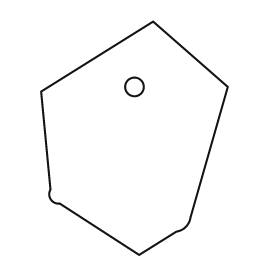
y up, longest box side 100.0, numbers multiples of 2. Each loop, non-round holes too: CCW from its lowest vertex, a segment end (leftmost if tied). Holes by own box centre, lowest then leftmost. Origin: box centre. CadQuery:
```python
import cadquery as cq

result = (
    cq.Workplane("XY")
    .moveTo(2.0, -50.0)
    .lineTo(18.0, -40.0)
    .threePointArc((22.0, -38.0), (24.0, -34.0))
    .lineTo(40.0, 22.0)
    .lineTo(8.0, 50.0)
    .lineTo(-40.0, 20.0)
    .lineTo(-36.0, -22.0)
    .threePointArc((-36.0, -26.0), (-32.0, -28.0))
    .close()
    .moveTo(0.0, 22.0)
    .circle(4.0)
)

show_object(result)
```